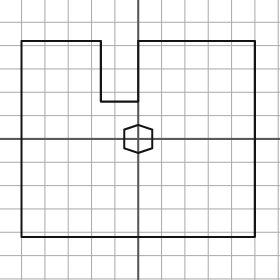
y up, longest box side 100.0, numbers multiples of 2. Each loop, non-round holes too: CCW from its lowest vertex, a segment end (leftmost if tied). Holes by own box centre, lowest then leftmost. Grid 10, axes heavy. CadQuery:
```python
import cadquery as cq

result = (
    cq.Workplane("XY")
    .moveTo(-50.0, -42.0)
    .lineTo(50.0, -42.0)
    .lineTo(50.0, 42.0)
    .lineTo(0.0, 42.0)
    .lineTo(0.0, 16.0)
    .lineTo(-16.0, 16.0)
    .lineTo(-16.0, 42.0)
    .lineTo(-50.0, 42.0)
    .close()
    .moveTo(0.0, -6.0)
    .lineTo(6.0, -4.0)
    .lineTo(6.0, 4.0)
    .lineTo(0.0, 6.0)
    .lineTo(-6.0, 4.0)
    .lineTo(-6.0, -4.0)
    .close()
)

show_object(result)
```